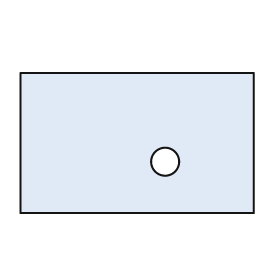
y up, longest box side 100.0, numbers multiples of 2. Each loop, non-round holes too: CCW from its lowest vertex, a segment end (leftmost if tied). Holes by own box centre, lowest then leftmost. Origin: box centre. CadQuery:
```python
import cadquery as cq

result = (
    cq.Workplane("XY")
    .moveTo(-50.0, -30.0)
    .lineTo(50.0, -30.0)
    .lineTo(50.0, 30.0)
    .lineTo(-50.0, 30.0)
    .close()
    .moveTo(12.0, -8.0)
    .circle(6.0)
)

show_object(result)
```